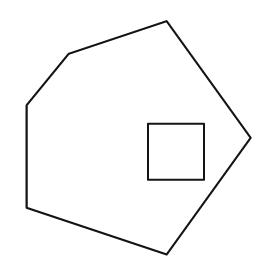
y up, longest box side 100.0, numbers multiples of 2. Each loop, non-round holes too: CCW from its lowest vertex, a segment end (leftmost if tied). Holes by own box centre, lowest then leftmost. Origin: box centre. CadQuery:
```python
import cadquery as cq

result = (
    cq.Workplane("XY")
    .moveTo(12.0, -50.0)
    .lineTo(48.0, 0.0)
    .lineTo(12.0, 50.0)
    .lineTo(-30.0, 36.0)
    .lineTo(-48.0, 14.0)
    .lineTo(-48.0, -30.0)
    .close()
    .moveTo(4.0, -18.0)
    .lineTo(28.0, -18.0)
    .lineTo(28.0, 6.0)
    .lineTo(4.0, 6.0)
    .close()
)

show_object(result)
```